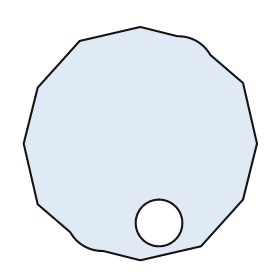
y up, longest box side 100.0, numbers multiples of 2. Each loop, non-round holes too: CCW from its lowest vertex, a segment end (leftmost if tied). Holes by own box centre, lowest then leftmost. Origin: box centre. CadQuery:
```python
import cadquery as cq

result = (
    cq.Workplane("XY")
    .moveTo(0.0, -50.0)
    .lineTo(26.0, -44.0)
    .lineTo(44.0, -24.0)
    .lineTo(50.0, 0.0)
    .lineTo(44.0, 26.0)
    .lineTo(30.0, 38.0)
    .threePointArc((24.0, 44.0), (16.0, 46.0))
    .lineTo(0.0, 50.0)
    .lineTo(-26.0, 44.0)
    .lineTo(-44.0, 24.0)
    .lineTo(-50.0, 0.0)
    .lineTo(-44.0, -26.0)
    .lineTo(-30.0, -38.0)
    .threePointArc((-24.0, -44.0), (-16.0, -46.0))
    .close()
    .moveTo(8.0, -34.0)
    .circle(10.0)
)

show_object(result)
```